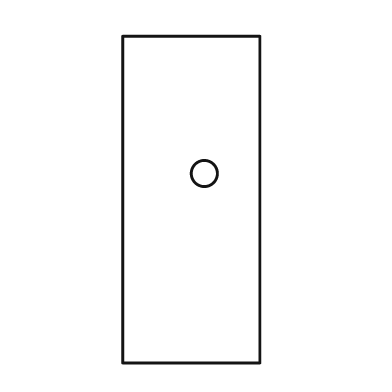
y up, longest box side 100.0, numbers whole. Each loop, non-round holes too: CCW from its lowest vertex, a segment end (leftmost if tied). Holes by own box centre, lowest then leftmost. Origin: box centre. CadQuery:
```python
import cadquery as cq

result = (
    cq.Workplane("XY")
    .moveTo(-21.0, -50.0)
    .lineTo(21.0, -50.0)
    .lineTo(21.0, 50.0)
    .lineTo(-21.0, 50.0)
    .close()
    .moveTo(4.0, 8.0)
    .circle(4.0)
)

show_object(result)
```